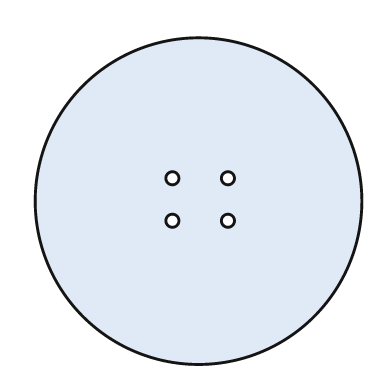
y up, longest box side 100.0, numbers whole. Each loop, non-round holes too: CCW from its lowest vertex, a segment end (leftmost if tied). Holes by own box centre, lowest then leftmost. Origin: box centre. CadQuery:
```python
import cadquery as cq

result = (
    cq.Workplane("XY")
    .moveTo(0.0, 0.0)
    .circle(50.0)
    .moveTo(-8.0, -6.0)
    .circle(2.0)
    .moveTo(9.0, -6.0)
    .circle(2.0)
    .moveTo(-8.0, 7.0)
    .circle(2.0)
    .moveTo(9.0, 7.0)
    .circle(2.0)
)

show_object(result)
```